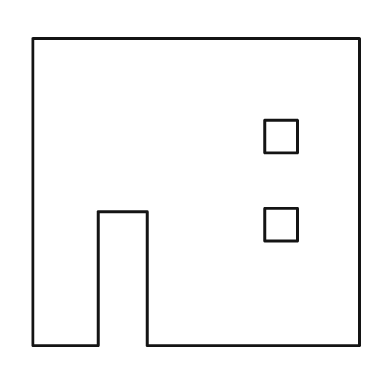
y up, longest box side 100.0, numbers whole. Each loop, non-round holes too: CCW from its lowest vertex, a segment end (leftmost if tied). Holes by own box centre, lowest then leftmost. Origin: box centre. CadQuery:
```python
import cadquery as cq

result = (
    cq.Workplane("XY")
    .moveTo(-50.0, -47.0)
    .lineTo(-30.0, -47.0)
    .lineTo(-30.0, -6.0)
    .lineTo(-15.0, -6.0)
    .lineTo(-15.0, -47.0)
    .lineTo(50.0, -47.0)
    .lineTo(50.0, 47.0)
    .lineTo(-50.0, 47.0)
    .close()
    .moveTo(21.0, -15.0)
    .lineTo(31.0, -15.0)
    .lineTo(31.0, -5.0)
    .lineTo(21.0, -5.0)
    .close()
    .moveTo(21.0, 12.0)
    .lineTo(31.0, 12.0)
    .lineTo(31.0, 22.0)
    .lineTo(21.0, 22.0)
    .close()
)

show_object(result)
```